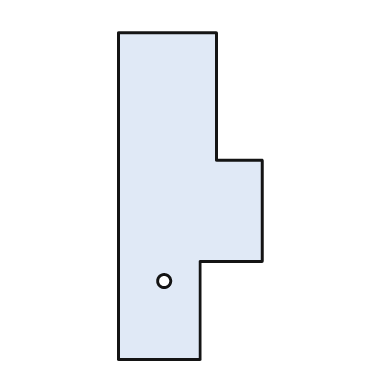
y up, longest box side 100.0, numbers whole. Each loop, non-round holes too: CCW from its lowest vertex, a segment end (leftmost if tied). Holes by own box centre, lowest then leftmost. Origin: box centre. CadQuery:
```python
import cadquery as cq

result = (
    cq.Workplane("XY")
    .moveTo(-22.0, -50.0)
    .lineTo(3.0, -50.0)
    .lineTo(3.0, -20.0)
    .lineTo(22.0, -20.0)
    .lineTo(22.0, 11.0)
    .lineTo(8.0, 11.0)
    .lineTo(8.0, 50.0)
    .lineTo(-22.0, 50.0)
    .close()
    .moveTo(-8.0, -26.0)
    .circle(2.0)
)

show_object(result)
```